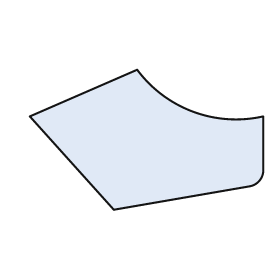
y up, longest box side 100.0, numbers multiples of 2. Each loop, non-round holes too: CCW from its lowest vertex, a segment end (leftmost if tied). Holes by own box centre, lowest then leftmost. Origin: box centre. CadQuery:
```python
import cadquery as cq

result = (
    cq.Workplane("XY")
    .moveTo(-14.0, -30.0)
    .lineTo(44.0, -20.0)
    .threePointArc((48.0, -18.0), (50.0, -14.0))
    .lineTo(50.0, 10.0)
    .threePointArc((20.0, 12.0), (-4.0, 30.0))
    .lineTo(-50.0, 10.0)
    .close()
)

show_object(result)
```